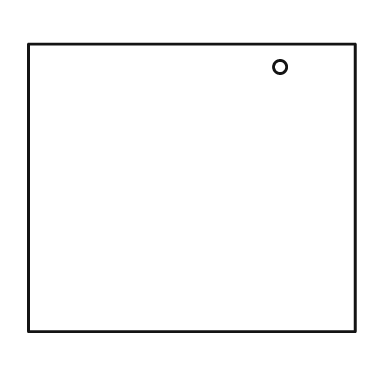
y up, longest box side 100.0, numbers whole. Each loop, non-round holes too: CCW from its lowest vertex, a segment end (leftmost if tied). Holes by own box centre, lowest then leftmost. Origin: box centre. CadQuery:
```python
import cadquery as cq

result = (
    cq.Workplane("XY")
    .moveTo(-50.0, -44.0)
    .lineTo(50.0, -44.0)
    .lineTo(50.0, 44.0)
    .lineTo(-50.0, 44.0)
    .close()
    .moveTo(27.0, 37.0)
    .circle(2.0)
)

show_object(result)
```